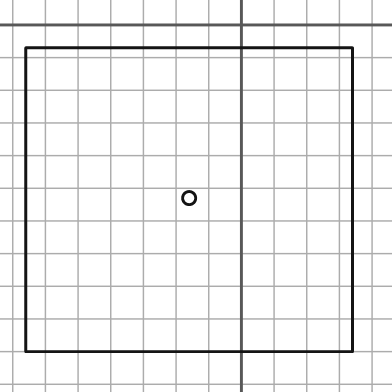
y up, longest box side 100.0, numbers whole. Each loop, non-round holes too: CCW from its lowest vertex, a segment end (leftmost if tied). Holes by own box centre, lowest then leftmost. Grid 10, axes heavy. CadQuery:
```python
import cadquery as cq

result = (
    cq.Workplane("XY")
    .moveTo(-66.0, -100.0)
    .lineTo(34.0, -100.0)
    .lineTo(34.0, -7.0)
    .lineTo(-66.0, -7.0)
    .close()
    .moveTo(-16.0, -53.0)
    .circle(2.0)
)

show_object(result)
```